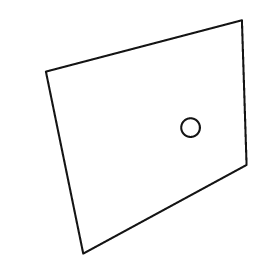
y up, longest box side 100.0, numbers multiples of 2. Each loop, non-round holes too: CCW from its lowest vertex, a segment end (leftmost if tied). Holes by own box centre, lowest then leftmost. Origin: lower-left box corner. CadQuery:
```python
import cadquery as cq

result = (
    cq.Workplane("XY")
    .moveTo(16.0, 0.0)
    .lineTo(86.0, 38.0)
    .lineTo(84.0, 100.0)
    .lineTo(0.0, 78.0)
    .close()
    .moveTo(62.0, 54.0)
    .circle(4.0)
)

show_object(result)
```